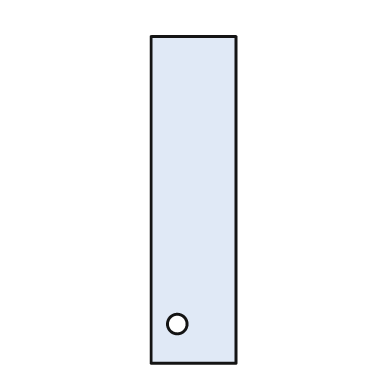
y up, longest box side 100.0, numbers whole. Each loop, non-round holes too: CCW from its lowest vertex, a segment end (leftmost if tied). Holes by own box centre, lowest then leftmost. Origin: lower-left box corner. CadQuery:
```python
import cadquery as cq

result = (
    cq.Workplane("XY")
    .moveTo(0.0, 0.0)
    .lineTo(26.0, 0.0)
    .lineTo(26.0, 100.0)
    .lineTo(0.0, 100.0)
    .close()
    .moveTo(8.0, 12.0)
    .circle(3.0)
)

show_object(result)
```